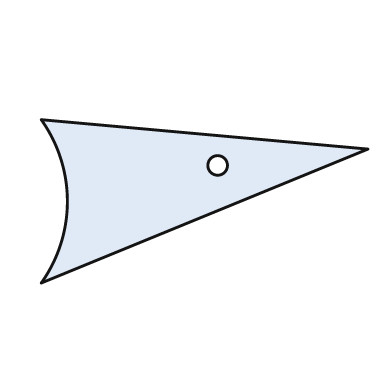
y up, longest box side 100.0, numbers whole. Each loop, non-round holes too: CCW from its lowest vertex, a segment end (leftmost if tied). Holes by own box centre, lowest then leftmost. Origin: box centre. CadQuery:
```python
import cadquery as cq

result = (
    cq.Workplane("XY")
    .moveTo(-50.0, -25.0)
    .lineTo(50.0, 16.0)
    .lineTo(-50.0, 25.0)
    .threePointArc((-42.0, 0.0), (-50.0, -25.0))
    .close()
    .moveTo(4.0, 11.0)
    .circle(3.0)
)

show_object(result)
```